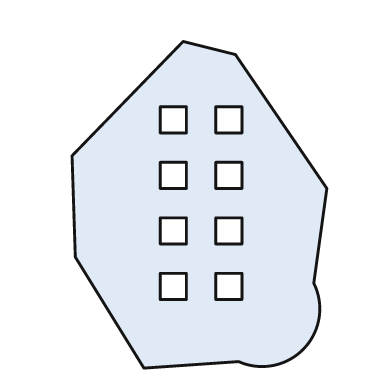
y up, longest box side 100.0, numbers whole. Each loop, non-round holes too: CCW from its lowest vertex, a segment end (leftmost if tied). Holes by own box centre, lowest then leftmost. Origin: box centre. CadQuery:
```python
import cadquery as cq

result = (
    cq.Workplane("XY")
    .moveTo(-17.0, -50.0)
    .lineTo(12.0, -48.0)
    .threePointArc((32.0, -44.0), (35.0, -24.0))
    .lineTo(39.0, 5.0)
    .lineTo(11.0, 46.0)
    .lineTo(-5.0, 50.0)
    .lineTo(-39.0, 15.0)
    .lineTo(-38.0, -16.0)
    .close()
    .moveTo(-12.0, -29.0)
    .lineTo(-4.0, -29.0)
    .lineTo(-4.0, -21.0)
    .lineTo(-12.0, -21.0)
    .close()
    .moveTo(5.0, -29.0)
    .lineTo(13.0, -29.0)
    .lineTo(13.0, -21.0)
    .lineTo(5.0, -21.0)
    .close()
    .moveTo(-12.0, -12.0)
    .lineTo(-4.0, -12.0)
    .lineTo(-4.0, -4.0)
    .lineTo(-12.0, -4.0)
    .close()
    .moveTo(5.0, -12.0)
    .lineTo(13.0, -12.0)
    .lineTo(13.0, -4.0)
    .lineTo(5.0, -4.0)
    .close()
    .moveTo(-12.0, 5.0)
    .lineTo(-4.0, 5.0)
    .lineTo(-4.0, 13.0)
    .lineTo(-12.0, 13.0)
    .close()
    .moveTo(5.0, 5.0)
    .lineTo(13.0, 5.0)
    .lineTo(13.0, 13.0)
    .lineTo(5.0, 13.0)
    .close()
    .moveTo(-12.0, 22.0)
    .lineTo(-4.0, 22.0)
    .lineTo(-4.0, 30.0)
    .lineTo(-12.0, 30.0)
    .close()
    .moveTo(5.0, 22.0)
    .lineTo(13.0, 22.0)
    .lineTo(13.0, 30.0)
    .lineTo(5.0, 30.0)
    .close()
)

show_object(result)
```